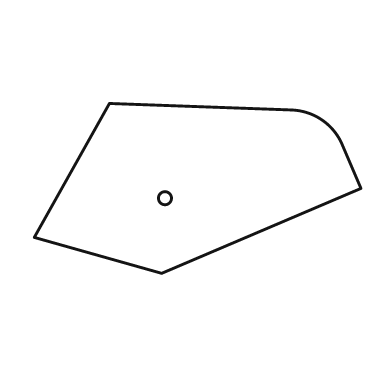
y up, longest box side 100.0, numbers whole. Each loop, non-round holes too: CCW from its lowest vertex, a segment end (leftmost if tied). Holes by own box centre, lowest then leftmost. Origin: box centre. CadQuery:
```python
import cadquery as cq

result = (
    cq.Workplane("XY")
    .moveTo(-11.0, -26.0)
    .lineTo(50.0, 0.0)
    .lineTo(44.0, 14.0)
    .threePointArc((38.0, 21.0), (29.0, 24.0))
    .lineTo(-27.0, 26.0)
    .lineTo(-50.0, -15.0)
    .close()
    .moveTo(-10.0, -3.0)
    .circle(2.0)
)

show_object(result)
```